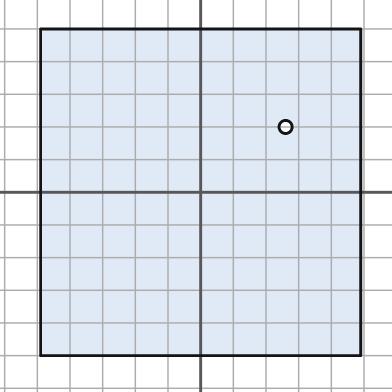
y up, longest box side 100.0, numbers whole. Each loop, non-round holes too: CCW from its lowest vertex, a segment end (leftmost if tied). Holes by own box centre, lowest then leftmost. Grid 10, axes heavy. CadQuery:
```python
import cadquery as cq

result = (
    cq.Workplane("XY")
    .moveTo(-49.0, -50.0)
    .lineTo(49.0, -50.0)
    .lineTo(49.0, 50.0)
    .lineTo(-49.0, 50.0)
    .close()
    .moveTo(26.0, 20.0)
    .circle(2.0)
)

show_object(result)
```